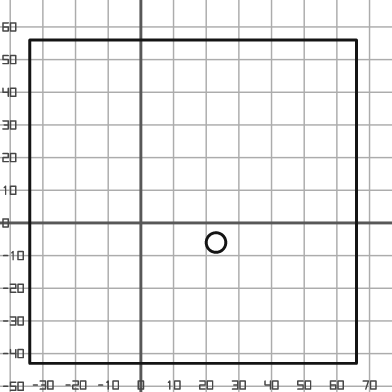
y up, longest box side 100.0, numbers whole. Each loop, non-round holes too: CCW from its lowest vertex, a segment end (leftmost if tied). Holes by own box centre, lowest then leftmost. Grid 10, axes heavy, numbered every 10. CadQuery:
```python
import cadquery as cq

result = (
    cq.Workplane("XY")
    .moveTo(-34.0, -43.0)
    .lineTo(66.0, -43.0)
    .lineTo(66.0, 56.0)
    .lineTo(-34.0, 56.0)
    .close()
    .moveTo(23.0, -6.0)
    .circle(3.0)
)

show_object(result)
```